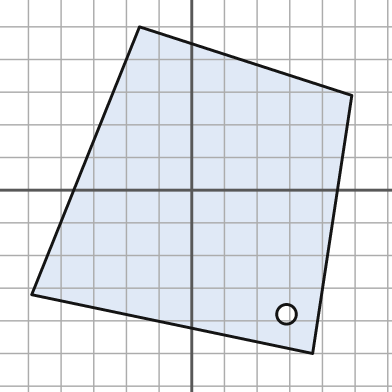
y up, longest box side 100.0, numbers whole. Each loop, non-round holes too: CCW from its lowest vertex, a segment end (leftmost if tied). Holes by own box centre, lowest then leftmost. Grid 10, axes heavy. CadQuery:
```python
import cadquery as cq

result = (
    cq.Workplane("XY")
    .moveTo(37.0, -50.0)
    .lineTo(49.0, 29.0)
    .lineTo(-16.0, 50.0)
    .lineTo(-49.0, -32.0)
    .close()
    .moveTo(29.0, -38.0)
    .circle(3.0)
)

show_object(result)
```